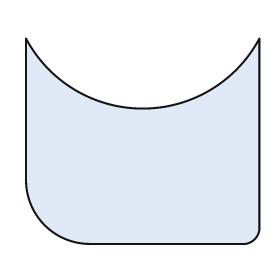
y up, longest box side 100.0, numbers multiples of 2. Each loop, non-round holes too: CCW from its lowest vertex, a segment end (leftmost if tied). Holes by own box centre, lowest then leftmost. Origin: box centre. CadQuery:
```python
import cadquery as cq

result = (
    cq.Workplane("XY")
    .moveTo(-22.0, -44.0)
    .lineTo(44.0, -44.0)
    .threePointArc((48.0, -42.0), (50.0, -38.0))
    .lineTo(50.0, 44.0)
    .threePointArc((0.0, 14.0), (-50.0, 44.0))
    .lineTo(-50.0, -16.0)
    .threePointArc((-42.0, -36.0), (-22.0, -44.0))
    .close()
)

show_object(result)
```